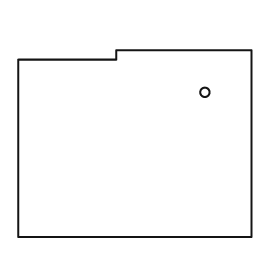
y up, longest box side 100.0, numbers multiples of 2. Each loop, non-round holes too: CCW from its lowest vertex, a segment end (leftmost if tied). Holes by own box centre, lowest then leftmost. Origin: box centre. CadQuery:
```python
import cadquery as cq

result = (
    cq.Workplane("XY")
    .moveTo(-50.0, -40.0)
    .lineTo(50.0, -40.0)
    .lineTo(50.0, 40.0)
    .lineTo(-8.0, 40.0)
    .lineTo(-8.0, 36.0)
    .lineTo(-50.0, 36.0)
    .close()
    .moveTo(30.0, 22.0)
    .circle(2.0)
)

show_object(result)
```